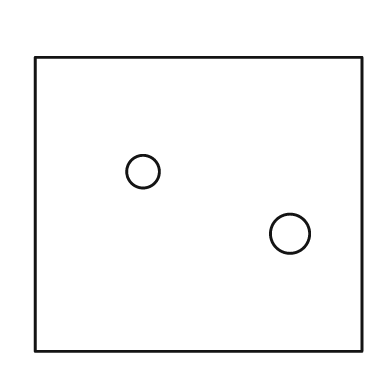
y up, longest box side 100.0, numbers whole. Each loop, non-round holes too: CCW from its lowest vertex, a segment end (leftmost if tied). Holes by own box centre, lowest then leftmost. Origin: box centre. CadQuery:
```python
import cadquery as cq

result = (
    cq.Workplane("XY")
    .moveTo(-50.0, -45.0)
    .lineTo(50.0, -45.0)
    .lineTo(50.0, 45.0)
    .lineTo(-50.0, 45.0)
    .close()
    .moveTo(28.0, -9.0)
    .circle(6.0)
    .moveTo(-17.0, 10.0)
    .circle(5.0)
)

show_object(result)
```